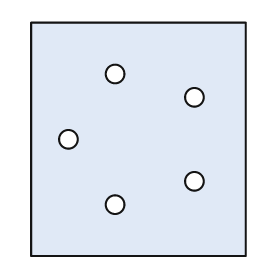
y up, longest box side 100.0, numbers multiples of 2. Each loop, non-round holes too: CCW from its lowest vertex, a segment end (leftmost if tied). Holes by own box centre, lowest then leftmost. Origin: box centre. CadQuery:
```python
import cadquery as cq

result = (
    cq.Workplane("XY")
    .moveTo(-46.0, -50.0)
    .lineTo(46.0, -50.0)
    .lineTo(46.0, 50.0)
    .lineTo(-46.0, 50.0)
    .close()
    .moveTo(-10.0, -28.0)
    .circle(4.0)
    .moveTo(24.0, -18.0)
    .circle(4.0)
    .moveTo(-30.0, 0.0)
    .circle(4.0)
    .moveTo(24.0, 18.0)
    .circle(4.0)
    .moveTo(-10.0, 28.0)
    .circle(4.0)
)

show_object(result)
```